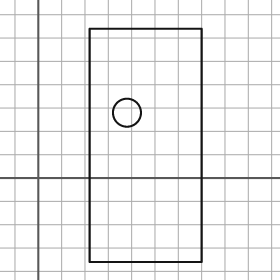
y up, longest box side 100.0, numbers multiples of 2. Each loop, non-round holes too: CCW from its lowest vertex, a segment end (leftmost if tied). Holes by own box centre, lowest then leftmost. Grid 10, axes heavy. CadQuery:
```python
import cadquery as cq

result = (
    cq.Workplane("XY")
    .moveTo(22.0, -36.0)
    .lineTo(70.0, -36.0)
    .lineTo(70.0, 64.0)
    .lineTo(22.0, 64.0)
    .close()
    .moveTo(38.0, 28.0)
    .circle(6.0)
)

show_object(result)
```